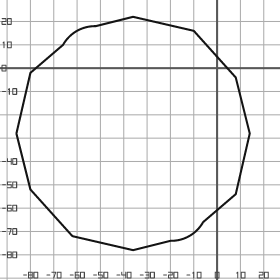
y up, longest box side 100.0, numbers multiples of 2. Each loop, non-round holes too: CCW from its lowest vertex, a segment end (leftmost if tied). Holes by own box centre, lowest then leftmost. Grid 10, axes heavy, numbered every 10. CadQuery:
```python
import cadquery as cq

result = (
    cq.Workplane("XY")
    .moveTo(-36.0, -78.0)
    .lineTo(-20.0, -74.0)
    .threePointArc((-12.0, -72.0), (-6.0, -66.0))
    .lineTo(8.0, -54.0)
    .lineTo(14.0, -28.0)
    .lineTo(8.0, -4.0)
    .lineTo(-10.0, 16.0)
    .lineTo(-36.0, 22.0)
    .lineTo(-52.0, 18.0)
    .threePointArc((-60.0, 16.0), (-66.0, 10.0))
    .lineTo(-80.0, -2.0)
    .lineTo(-86.0, -28.0)
    .lineTo(-80.0, -52.0)
    .lineTo(-62.0, -72.0)
    .close()
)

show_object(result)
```